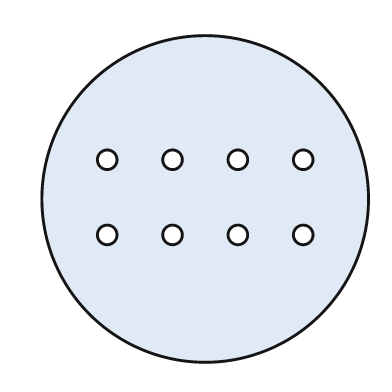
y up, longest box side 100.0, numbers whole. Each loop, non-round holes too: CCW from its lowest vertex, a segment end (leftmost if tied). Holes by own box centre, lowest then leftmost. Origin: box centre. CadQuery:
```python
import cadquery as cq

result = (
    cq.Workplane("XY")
    .moveTo(0.0, 0.0)
    .circle(50.0)
    .moveTo(-30.0, -11.0)
    .circle(3.0)
    .moveTo(-10.0, -11.0)
    .circle(3.0)
    .moveTo(10.0, -11.0)
    .circle(3.0)
    .moveTo(30.0, -11.0)
    .circle(3.0)
    .moveTo(-30.0, 12.0)
    .circle(3.0)
    .moveTo(-10.0, 12.0)
    .circle(3.0)
    .moveTo(10.0, 12.0)
    .circle(3.0)
    .moveTo(30.0, 12.0)
    .circle(3.0)
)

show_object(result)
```